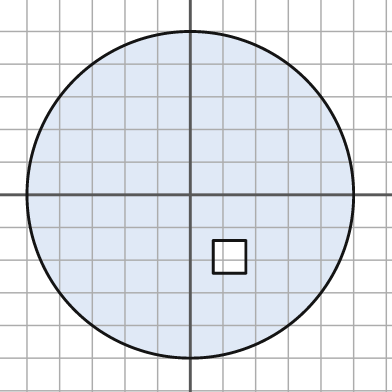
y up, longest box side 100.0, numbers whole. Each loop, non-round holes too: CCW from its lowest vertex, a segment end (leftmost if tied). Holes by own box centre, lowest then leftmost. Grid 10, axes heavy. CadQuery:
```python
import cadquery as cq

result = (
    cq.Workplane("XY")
    .moveTo(0.0, 0.0)
    .circle(50.0)
    .moveTo(7.0, -24.0)
    .lineTo(17.0, -24.0)
    .lineTo(17.0, -14.0)
    .lineTo(7.0, -14.0)
    .close()
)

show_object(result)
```